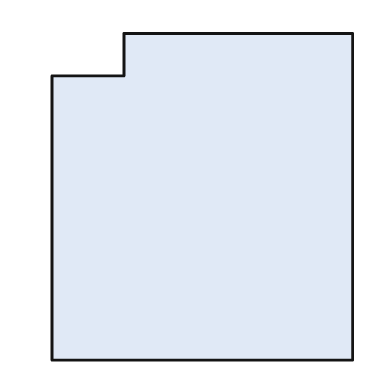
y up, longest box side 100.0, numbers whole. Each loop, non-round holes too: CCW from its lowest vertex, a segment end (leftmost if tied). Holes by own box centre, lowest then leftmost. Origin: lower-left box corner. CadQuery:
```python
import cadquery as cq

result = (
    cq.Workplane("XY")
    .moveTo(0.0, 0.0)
    .lineTo(92.0, 0.0)
    .lineTo(92.0, 100.0)
    .lineTo(22.0, 100.0)
    .lineTo(22.0, 87.0)
    .lineTo(0.0, 87.0)
    .close()
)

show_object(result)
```